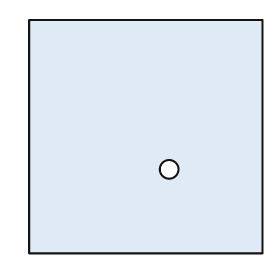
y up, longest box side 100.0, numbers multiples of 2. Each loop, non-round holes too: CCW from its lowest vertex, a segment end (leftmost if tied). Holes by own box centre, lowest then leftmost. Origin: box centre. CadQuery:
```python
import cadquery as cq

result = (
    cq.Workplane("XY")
    .moveTo(-50.0, -50.0)
    .lineTo(50.0, -50.0)
    .lineTo(50.0, 50.0)
    .lineTo(-50.0, 50.0)
    .close()
    .moveTo(10.0, -14.0)
    .circle(4.0)
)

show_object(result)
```